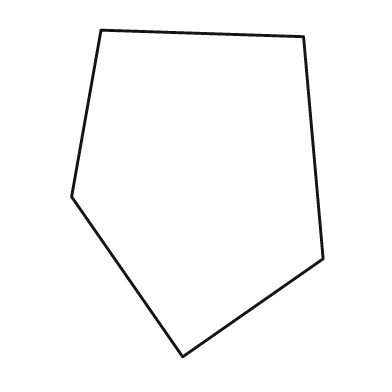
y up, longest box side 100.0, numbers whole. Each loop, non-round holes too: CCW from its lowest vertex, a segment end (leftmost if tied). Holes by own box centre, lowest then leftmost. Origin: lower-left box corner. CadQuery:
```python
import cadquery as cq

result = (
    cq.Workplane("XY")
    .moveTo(34.0, 0.0)
    .lineTo(77.0, 30.0)
    .lineTo(71.0, 98.0)
    .lineTo(9.0, 100.0)
    .lineTo(0.0, 49.0)
    .close()
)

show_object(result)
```